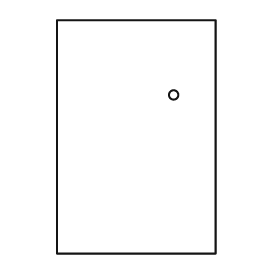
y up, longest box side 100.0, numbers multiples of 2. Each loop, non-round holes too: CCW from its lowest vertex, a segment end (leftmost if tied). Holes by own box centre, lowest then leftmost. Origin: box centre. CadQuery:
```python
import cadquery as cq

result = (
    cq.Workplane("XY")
    .moveTo(-34.0, -50.0)
    .lineTo(34.0, -50.0)
    .lineTo(34.0, 50.0)
    .lineTo(-34.0, 50.0)
    .close()
    .moveTo(16.0, 18.0)
    .circle(2.0)
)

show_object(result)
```